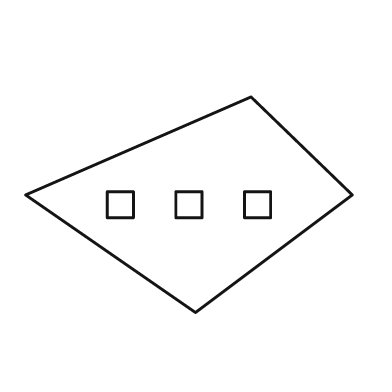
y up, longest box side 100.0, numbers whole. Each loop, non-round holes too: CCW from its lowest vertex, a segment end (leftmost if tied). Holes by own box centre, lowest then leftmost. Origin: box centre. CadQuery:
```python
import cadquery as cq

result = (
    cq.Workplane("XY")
    .moveTo(2.0, -33.0)
    .lineTo(50.0, 3.0)
    .lineTo(19.0, 33.0)
    .lineTo(-50.0, 3.0)
    .close()
    .moveTo(-25.0, -4.0)
    .lineTo(-17.0, -4.0)
    .lineTo(-17.0, 4.0)
    .lineTo(-25.0, 4.0)
    .close()
    .moveTo(-4.0, -4.0)
    .lineTo(4.0, -4.0)
    .lineTo(4.0, 4.0)
    .lineTo(-4.0, 4.0)
    .close()
    .moveTo(17.0, -4.0)
    .lineTo(25.0, -4.0)
    .lineTo(25.0, 4.0)
    .lineTo(17.0, 4.0)
    .close()
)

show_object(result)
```